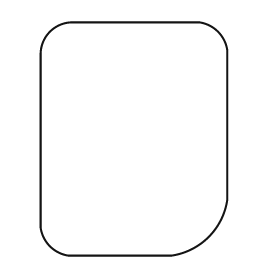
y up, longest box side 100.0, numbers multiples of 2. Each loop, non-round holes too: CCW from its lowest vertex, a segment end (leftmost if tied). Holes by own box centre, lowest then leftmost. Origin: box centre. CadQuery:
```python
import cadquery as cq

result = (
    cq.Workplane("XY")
    .moveTo(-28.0, -50.0)
    .lineTo(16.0, -50.0)
    .threePointArc((32.0, -42.0), (40.0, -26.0))
    .lineTo(40.0, 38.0)
    .threePointArc((36.0, 46.0), (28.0, 50.0))
    .lineTo(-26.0, 50.0)
    .threePointArc((-36.0, 46.0), (-40.0, 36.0))
    .lineTo(-40.0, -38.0)
    .threePointArc((-36.0, -46.0), (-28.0, -50.0))
    .close()
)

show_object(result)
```